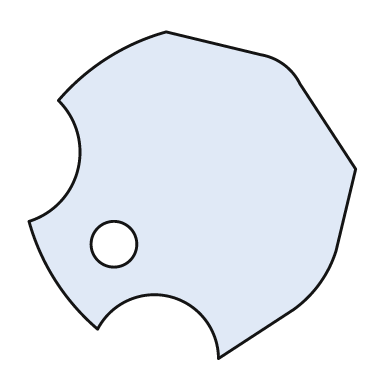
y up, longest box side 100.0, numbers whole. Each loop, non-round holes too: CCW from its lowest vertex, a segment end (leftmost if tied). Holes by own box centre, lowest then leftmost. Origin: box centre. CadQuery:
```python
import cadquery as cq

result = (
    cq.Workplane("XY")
    .moveTo(8.0, -50.0)
    .lineTo(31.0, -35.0)
    .threePointArc((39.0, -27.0), (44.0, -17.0))
    .lineTo(50.0, 8.0)
    .lineTo(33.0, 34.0)
    .threePointArc((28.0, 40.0), (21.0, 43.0))
    .lineTo(-8.0, 50.0)
    .threePointArc((-26.0, 42.0), (-41.0, 29.0))
    .threePointArc((-35.0, 8.0), (-50.0, -8.0))
    .threePointArc((-42.0, -26.0), (-29.0, -41.0))
    .threePointArc((-7.0, -31.0), (8.0, -50.0))
    .close()
    .moveTo(-24.0, -15.0)
    .circle(7.0)
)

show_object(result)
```